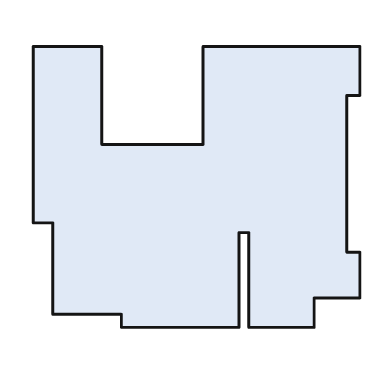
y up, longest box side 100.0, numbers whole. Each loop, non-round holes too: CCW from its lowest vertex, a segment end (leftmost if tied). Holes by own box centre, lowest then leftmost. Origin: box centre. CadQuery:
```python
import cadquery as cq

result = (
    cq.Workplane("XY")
    .moveTo(-23.0, -43.0)
    .lineTo(13.0, -43.0)
    .lineTo(13.0, -14.0)
    .lineTo(16.0, -14.0)
    .lineTo(16.0, -43.0)
    .lineTo(36.0, -43.0)
    .lineTo(36.0, -34.0)
    .lineTo(50.0, -34.0)
    .lineTo(50.0, -20.0)
    .lineTo(46.0, -20.0)
    .lineTo(46.0, 28.0)
    .lineTo(50.0, 28.0)
    .lineTo(50.0, 43.0)
    .lineTo(2.0, 43.0)
    .lineTo(2.0, 13.0)
    .lineTo(-29.0, 13.0)
    .lineTo(-29.0, 43.0)
    .lineTo(-50.0, 43.0)
    .lineTo(-50.0, -11.0)
    .lineTo(-44.0, -11.0)
    .lineTo(-44.0, -39.0)
    .lineTo(-23.0, -39.0)
    .close()
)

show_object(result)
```